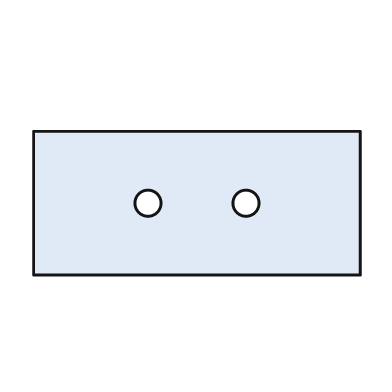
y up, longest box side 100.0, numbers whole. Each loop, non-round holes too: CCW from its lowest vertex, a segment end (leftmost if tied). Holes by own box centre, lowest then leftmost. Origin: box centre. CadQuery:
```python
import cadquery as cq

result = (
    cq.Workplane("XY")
    .moveTo(-50.0, -22.0)
    .lineTo(50.0, -22.0)
    .lineTo(50.0, 22.0)
    .lineTo(-50.0, 22.0)
    .close()
    .moveTo(-15.0, 0.0)
    .circle(4.0)
    .moveTo(15.0, 0.0)
    .circle(4.0)
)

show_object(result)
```